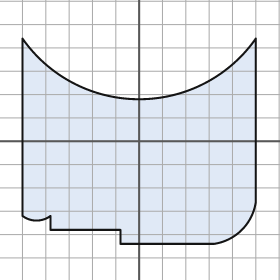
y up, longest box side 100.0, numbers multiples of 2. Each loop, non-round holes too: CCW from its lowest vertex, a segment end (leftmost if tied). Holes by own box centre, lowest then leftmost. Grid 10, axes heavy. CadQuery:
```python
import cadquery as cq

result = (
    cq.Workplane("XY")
    .moveTo(-8.0, -44.0)
    .lineTo(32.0, -44.0)
    .threePointArc((44.0, -38.0), (50.0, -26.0))
    .lineTo(50.0, 44.0)
    .threePointArc((0.0, 18.0), (-50.0, 44.0))
    .lineTo(-50.0, -32.0)
    .threePointArc((-44.0, -34.0), (-38.0, -32.0))
    .lineTo(-38.0, -38.0)
    .lineTo(-8.0, -38.0)
    .close()
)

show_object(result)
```